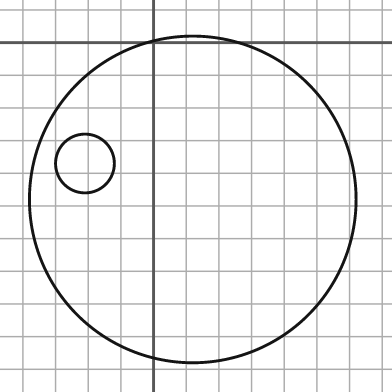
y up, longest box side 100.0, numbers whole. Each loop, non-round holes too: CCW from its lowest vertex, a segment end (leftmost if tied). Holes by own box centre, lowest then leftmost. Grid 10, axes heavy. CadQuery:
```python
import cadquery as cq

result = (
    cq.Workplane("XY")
    .moveTo(12.0, -48.0)
    .circle(50.0)
    .moveTo(-21.0, -37.0)
    .circle(9.0)
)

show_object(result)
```